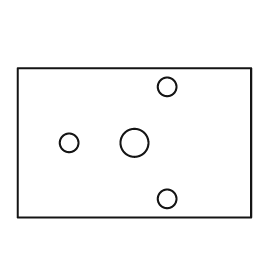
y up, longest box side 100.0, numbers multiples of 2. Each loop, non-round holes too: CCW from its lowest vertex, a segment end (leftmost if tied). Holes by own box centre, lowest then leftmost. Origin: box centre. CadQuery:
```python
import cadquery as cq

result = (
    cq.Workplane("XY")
    .moveTo(-50.0, -32.0)
    .lineTo(50.0, -32.0)
    .lineTo(50.0, 32.0)
    .lineTo(-50.0, 32.0)
    .close()
    .moveTo(14.0, -24.0)
    .circle(4.0)
    .moveTo(-28.0, 0.0)
    .circle(4.0)
    .moveTo(0.0, 0.0)
    .circle(6.0)
    .moveTo(14.0, 24.0)
    .circle(4.0)
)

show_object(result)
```